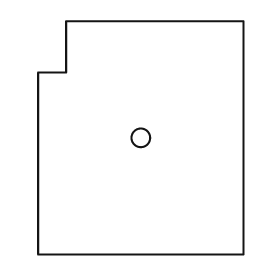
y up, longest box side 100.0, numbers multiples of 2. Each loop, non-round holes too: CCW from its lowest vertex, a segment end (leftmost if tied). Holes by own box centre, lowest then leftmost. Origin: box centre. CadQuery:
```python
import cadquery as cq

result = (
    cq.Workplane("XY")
    .moveTo(-44.0, -50.0)
    .lineTo(44.0, -50.0)
    .lineTo(44.0, 50.0)
    .lineTo(-32.0, 50.0)
    .lineTo(-32.0, 28.0)
    .lineTo(-44.0, 28.0)
    .close()
    .moveTo(0.0, 0.0)
    .circle(4.0)
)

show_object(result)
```